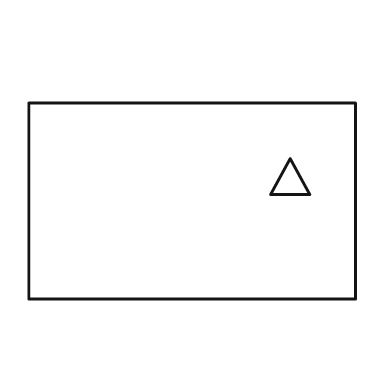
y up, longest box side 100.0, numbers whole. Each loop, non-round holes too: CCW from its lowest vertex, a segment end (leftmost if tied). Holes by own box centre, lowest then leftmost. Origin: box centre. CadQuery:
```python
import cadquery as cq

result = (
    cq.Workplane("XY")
    .moveTo(-50.0, -30.0)
    .lineTo(50.0, -30.0)
    .lineTo(50.0, 30.0)
    .lineTo(-50.0, 30.0)
    .close()
    .moveTo(24.0, 2.0)
    .lineTo(36.0, 2.0)
    .lineTo(30.0, 13.0)
    .close()
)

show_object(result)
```